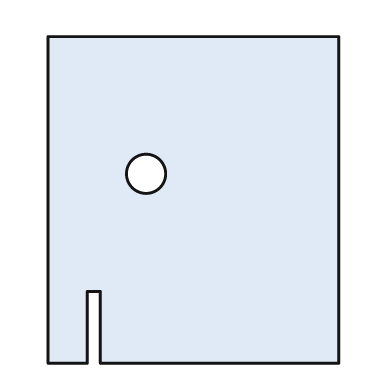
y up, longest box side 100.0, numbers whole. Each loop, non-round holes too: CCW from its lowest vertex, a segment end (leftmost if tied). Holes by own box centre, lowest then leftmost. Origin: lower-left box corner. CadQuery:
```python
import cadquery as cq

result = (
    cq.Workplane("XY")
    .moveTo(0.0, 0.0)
    .lineTo(12.0, 0.0)
    .lineTo(12.0, 22.0)
    .lineTo(16.0, 22.0)
    .lineTo(16.0, 0.0)
    .lineTo(89.0, 0.0)
    .lineTo(89.0, 100.0)
    .lineTo(0.0, 100.0)
    .close()
    .moveTo(30.0, 58.0)
    .circle(6.0)
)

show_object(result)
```